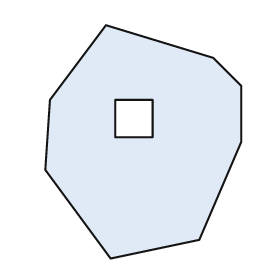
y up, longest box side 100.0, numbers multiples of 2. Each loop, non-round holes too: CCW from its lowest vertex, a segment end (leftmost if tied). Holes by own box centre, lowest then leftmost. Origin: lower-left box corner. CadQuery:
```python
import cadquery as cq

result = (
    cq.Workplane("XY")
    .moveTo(28.0, 0.0)
    .lineTo(66.0, 8.0)
    .lineTo(84.0, 50.0)
    .lineTo(84.0, 74.0)
    .lineTo(72.0, 86.0)
    .lineTo(26.0, 100.0)
    .lineTo(2.0, 68.0)
    .lineTo(0.0, 38.0)
    .close()
    .moveTo(30.0, 52.0)
    .lineTo(46.0, 52.0)
    .lineTo(46.0, 68.0)
    .lineTo(30.0, 68.0)
    .close()
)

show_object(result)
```